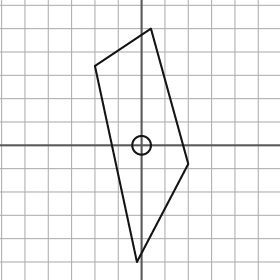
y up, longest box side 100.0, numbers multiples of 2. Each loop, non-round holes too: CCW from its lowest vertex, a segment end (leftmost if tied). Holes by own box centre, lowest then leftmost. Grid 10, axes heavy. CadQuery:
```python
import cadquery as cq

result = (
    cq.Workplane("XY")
    .moveTo(-2.0, -50.0)
    .lineTo(20.0, -8.0)
    .lineTo(4.0, 50.0)
    .lineTo(-20.0, 34.0)
    .close()
    .moveTo(0.0, 0.0)
    .circle(4.0)
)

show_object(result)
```